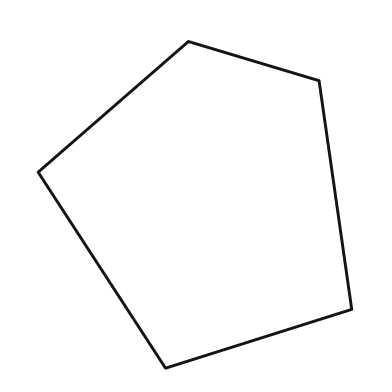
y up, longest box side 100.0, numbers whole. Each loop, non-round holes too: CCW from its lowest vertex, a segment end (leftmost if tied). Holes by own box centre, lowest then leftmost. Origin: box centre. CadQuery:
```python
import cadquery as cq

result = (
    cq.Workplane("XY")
    .moveTo(-9.0, -50.0)
    .lineTo(48.0, -32.0)
    .lineTo(38.0, 38.0)
    .lineTo(-2.0, 50.0)
    .lineTo(-48.0, 10.0)
    .close()
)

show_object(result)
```